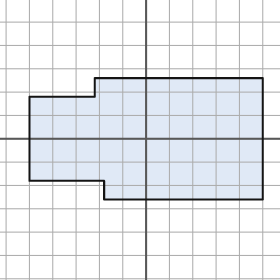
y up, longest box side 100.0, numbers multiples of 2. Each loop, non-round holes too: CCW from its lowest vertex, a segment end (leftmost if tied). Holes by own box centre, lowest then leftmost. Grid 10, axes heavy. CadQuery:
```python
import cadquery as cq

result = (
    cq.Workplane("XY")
    .moveTo(-18.0, -26.0)
    .lineTo(50.0, -26.0)
    .lineTo(50.0, 26.0)
    .lineTo(-22.0, 26.0)
    .lineTo(-22.0, 18.0)
    .lineTo(-50.0, 18.0)
    .lineTo(-50.0, -18.0)
    .lineTo(-18.0, -18.0)
    .close()
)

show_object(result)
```